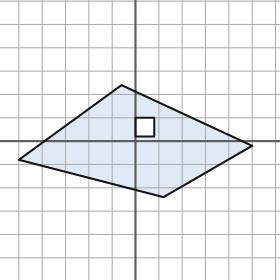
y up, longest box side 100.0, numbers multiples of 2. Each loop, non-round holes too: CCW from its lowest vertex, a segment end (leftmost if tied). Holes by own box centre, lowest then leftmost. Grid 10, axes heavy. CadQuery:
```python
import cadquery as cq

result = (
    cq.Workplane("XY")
    .moveTo(12.0, -24.0)
    .lineTo(50.0, -2.0)
    .lineTo(-6.0, 24.0)
    .lineTo(-50.0, -8.0)
    .close()
    .moveTo(0.0, 2.0)
    .lineTo(8.0, 2.0)
    .lineTo(8.0, 10.0)
    .lineTo(0.0, 10.0)
    .close()
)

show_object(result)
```